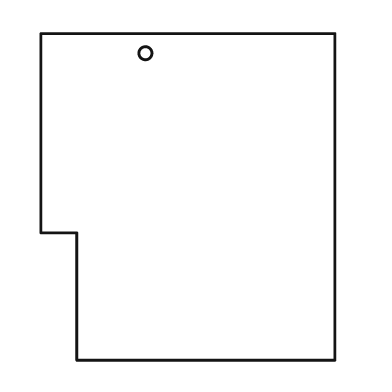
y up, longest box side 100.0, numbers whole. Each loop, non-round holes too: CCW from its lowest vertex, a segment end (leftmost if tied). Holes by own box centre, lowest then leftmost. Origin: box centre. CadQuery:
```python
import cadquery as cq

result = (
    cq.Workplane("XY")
    .moveTo(-34.0, -50.0)
    .lineTo(45.0, -50.0)
    .lineTo(45.0, 50.0)
    .lineTo(-45.0, 50.0)
    .lineTo(-45.0, -11.0)
    .lineTo(-34.0, -11.0)
    .close()
    .moveTo(-13.0, 44.0)
    .circle(2.0)
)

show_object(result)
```